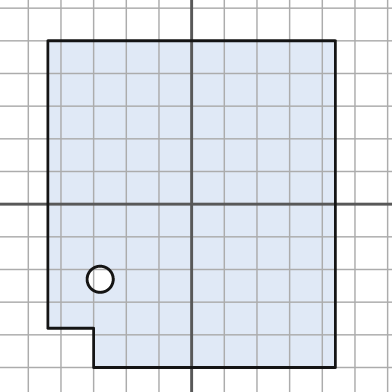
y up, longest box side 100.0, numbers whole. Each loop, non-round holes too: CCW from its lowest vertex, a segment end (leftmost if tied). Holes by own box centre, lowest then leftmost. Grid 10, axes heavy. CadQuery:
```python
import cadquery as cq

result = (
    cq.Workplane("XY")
    .moveTo(-30.0, -50.0)
    .lineTo(44.0, -50.0)
    .lineTo(44.0, 50.0)
    .lineTo(-44.0, 50.0)
    .lineTo(-44.0, -38.0)
    .lineTo(-30.0, -38.0)
    .close()
    .moveTo(-28.0, -23.0)
    .circle(4.0)
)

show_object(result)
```